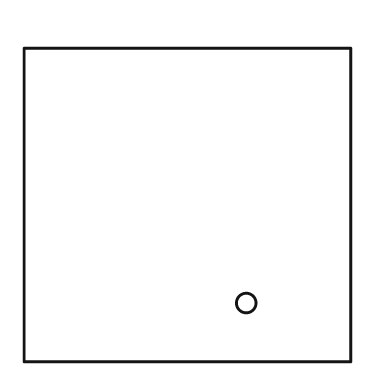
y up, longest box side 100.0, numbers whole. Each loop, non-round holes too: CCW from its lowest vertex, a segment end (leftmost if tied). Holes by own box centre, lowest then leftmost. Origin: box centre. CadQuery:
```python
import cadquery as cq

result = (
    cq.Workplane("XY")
    .moveTo(-50.0, -48.0)
    .lineTo(50.0, -48.0)
    .lineTo(50.0, 48.0)
    .lineTo(-50.0, 48.0)
    .close()
    .moveTo(18.0, -30.0)
    .circle(3.0)
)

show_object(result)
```